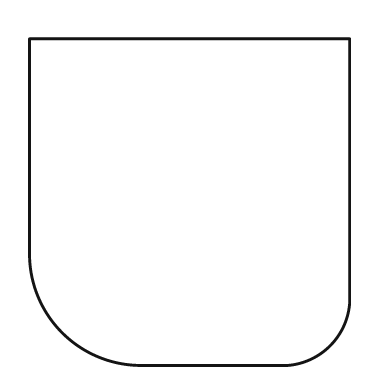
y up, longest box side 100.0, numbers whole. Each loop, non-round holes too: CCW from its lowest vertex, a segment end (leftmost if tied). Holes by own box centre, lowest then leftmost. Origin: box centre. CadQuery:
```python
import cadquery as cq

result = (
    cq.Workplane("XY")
    .moveTo(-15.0, -50.0)
    .lineTo(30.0, -50.0)
    .threePointArc((43.0, -44.0), (49.0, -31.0))
    .lineTo(49.0, 50.0)
    .lineTo(-49.0, 50.0)
    .lineTo(-49.0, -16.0)
    .threePointArc((-39.0, -40.0), (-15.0, -50.0))
    .close()
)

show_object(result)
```